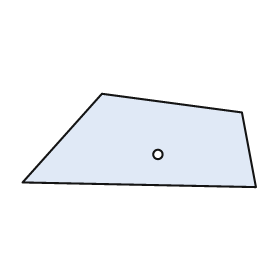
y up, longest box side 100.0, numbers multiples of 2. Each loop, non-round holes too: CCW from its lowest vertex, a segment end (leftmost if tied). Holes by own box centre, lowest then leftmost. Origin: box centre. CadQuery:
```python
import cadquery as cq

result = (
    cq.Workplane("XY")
    .moveTo(50.0, -20.0)
    .lineTo(44.0, 12.0)
    .lineTo(-16.0, 20.0)
    .lineTo(-50.0, -18.0)
    .close()
    .moveTo(8.0, -6.0)
    .circle(2.0)
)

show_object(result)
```